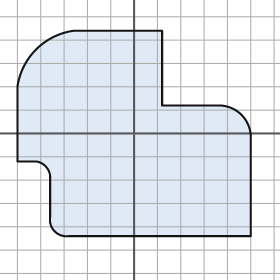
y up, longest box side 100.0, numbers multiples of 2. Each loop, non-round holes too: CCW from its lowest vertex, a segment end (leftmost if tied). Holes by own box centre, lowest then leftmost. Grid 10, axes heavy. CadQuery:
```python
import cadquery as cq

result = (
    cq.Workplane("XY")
    .moveTo(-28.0, -44.0)
    .lineTo(50.0, -44.0)
    .lineTo(50.0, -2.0)
    .threePointArc((46.0, 8.0), (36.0, 12.0))
    .lineTo(12.0, 12.0)
    .lineTo(12.0, 44.0)
    .lineTo(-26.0, 44.0)
    .threePointArc((-42.0, 36.0), (-50.0, 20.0))
    .lineTo(-50.0, -12.0)
    .lineTo(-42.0, -12.0)
    .threePointArc((-38.0, -14.0), (-36.0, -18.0))
    .lineTo(-36.0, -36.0)
    .threePointArc((-34.0, -42.0), (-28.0, -44.0))
    .close()
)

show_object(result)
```